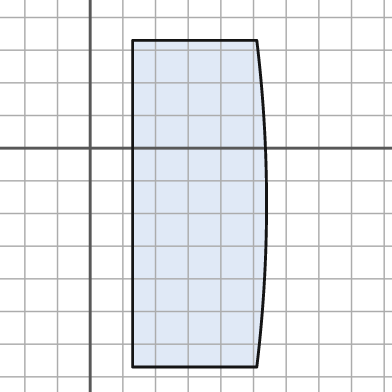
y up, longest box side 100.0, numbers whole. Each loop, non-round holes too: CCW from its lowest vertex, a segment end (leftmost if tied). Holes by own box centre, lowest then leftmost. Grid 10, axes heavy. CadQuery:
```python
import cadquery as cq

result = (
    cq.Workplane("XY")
    .moveTo(13.0, -67.0)
    .lineTo(51.0, -67.0)
    .threePointArc((54.0, -17.0), (51.0, 33.0))
    .lineTo(13.0, 33.0)
    .close()
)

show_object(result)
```